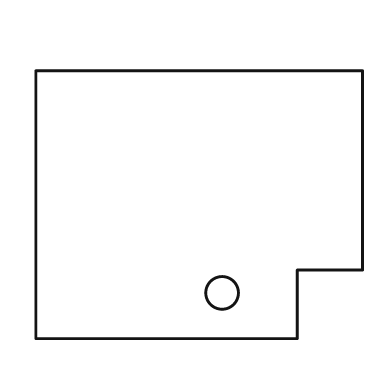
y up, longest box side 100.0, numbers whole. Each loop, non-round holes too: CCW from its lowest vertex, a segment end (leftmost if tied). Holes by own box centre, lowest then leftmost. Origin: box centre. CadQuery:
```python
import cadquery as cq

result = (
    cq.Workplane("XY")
    .moveTo(-50.0, -41.0)
    .lineTo(30.0, -41.0)
    .lineTo(30.0, -20.0)
    .lineTo(50.0, -20.0)
    .lineTo(50.0, 41.0)
    .lineTo(-50.0, 41.0)
    .close()
    .moveTo(7.0, -27.0)
    .circle(5.0)
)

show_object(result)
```